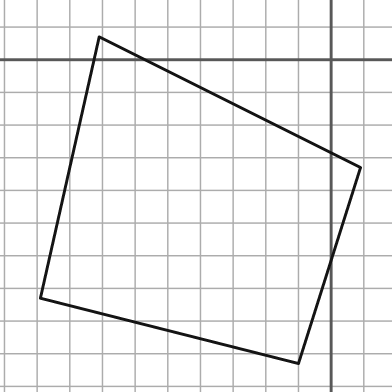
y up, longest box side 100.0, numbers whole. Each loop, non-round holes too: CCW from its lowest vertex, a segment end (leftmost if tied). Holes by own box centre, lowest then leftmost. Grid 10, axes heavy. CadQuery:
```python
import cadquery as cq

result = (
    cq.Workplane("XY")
    .moveTo(-10.0, -93.0)
    .lineTo(9.0, -33.0)
    .lineTo(-71.0, 7.0)
    .lineTo(-89.0, -73.0)
    .close()
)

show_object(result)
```